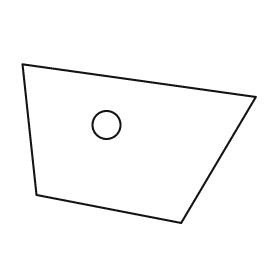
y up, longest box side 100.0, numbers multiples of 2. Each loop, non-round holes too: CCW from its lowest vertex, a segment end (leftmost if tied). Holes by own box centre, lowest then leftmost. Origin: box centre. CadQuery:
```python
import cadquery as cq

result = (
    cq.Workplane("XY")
    .moveTo(18.0, -34.0)
    .lineTo(50.0, 20.0)
    .lineTo(-50.0, 34.0)
    .lineTo(-44.0, -22.0)
    .close()
    .moveTo(-14.0, 8.0)
    .circle(6.0)
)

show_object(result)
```